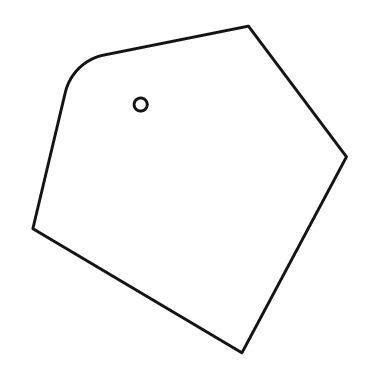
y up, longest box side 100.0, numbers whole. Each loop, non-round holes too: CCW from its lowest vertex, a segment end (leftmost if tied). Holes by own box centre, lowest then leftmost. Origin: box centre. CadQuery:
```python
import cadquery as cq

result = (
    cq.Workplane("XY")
    .moveTo(16.0, -50.0)
    .lineTo(48.0, 10.0)
    .lineTo(18.0, 50.0)
    .lineTo(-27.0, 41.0)
    .threePointArc((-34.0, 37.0), (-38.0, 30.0))
    .lineTo(-48.0, -12.0)
    .close()
    .moveTo(-15.0, 26.0)
    .circle(2.0)
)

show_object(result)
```